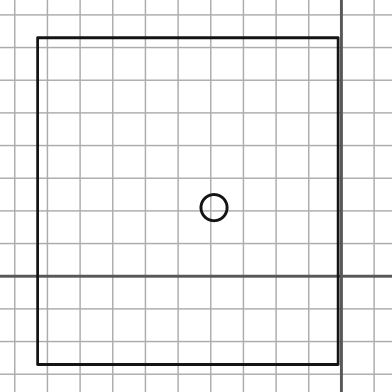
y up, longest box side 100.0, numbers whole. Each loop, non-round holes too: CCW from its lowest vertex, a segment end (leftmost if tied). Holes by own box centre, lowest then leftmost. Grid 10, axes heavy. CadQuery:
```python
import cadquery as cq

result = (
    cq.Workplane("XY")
    .moveTo(-93.0, -27.0)
    .lineTo(-1.0, -27.0)
    .lineTo(-1.0, 73.0)
    .lineTo(-93.0, 73.0)
    .close()
    .moveTo(-39.0, 21.0)
    .circle(4.0)
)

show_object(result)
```